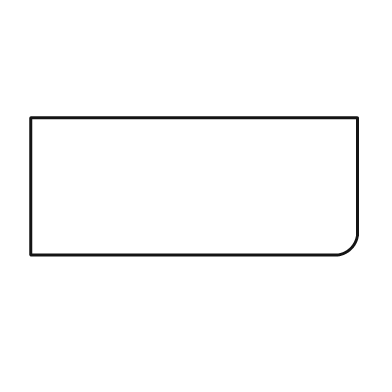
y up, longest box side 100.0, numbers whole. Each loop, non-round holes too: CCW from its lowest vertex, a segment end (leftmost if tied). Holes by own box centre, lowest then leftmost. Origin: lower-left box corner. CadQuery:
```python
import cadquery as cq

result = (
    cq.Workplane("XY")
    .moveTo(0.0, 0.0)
    .lineTo(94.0, 0.0)
    .threePointArc((98.0, 2.0), (100.0, 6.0))
    .lineTo(100.0, 42.0)
    .lineTo(0.0, 42.0)
    .close()
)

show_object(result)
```